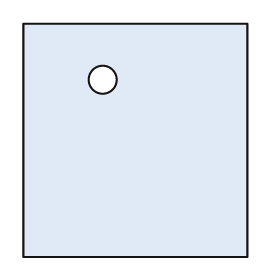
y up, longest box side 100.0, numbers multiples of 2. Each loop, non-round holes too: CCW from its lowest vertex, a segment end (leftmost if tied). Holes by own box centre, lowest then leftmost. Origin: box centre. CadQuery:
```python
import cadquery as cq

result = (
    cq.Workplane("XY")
    .moveTo(-48.0, -50.0)
    .lineTo(48.0, -50.0)
    .lineTo(48.0, 50.0)
    .lineTo(-48.0, 50.0)
    .close()
    .moveTo(-14.0, 26.0)
    .circle(6.0)
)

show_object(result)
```